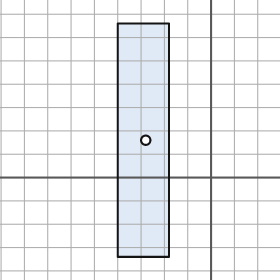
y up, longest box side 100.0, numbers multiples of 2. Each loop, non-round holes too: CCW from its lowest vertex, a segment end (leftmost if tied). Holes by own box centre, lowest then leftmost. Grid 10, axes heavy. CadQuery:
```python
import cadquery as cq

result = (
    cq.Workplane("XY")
    .moveTo(-40.0, -34.0)
    .lineTo(-18.0, -34.0)
    .lineTo(-18.0, 66.0)
    .lineTo(-40.0, 66.0)
    .close()
    .moveTo(-28.0, 16.0)
    .circle(2.0)
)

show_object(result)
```